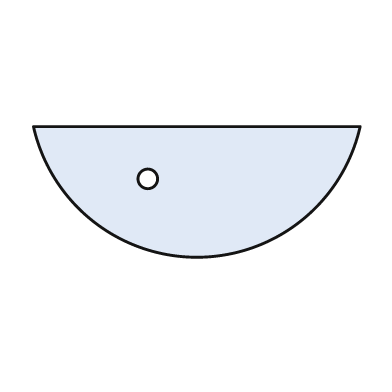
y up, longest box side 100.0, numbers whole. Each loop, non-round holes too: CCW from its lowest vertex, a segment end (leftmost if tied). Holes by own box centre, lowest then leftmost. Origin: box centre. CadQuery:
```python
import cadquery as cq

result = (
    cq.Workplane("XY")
    .moveTo(-50.0, 20.0)
    .threePointArc((0.0, -20.0), (50.0, 20.0))
    .close()
    .moveTo(-15.0, 4.0)
    .circle(3.0)
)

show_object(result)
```